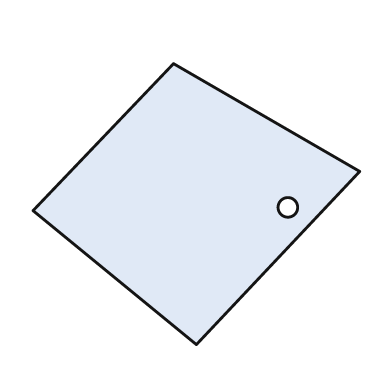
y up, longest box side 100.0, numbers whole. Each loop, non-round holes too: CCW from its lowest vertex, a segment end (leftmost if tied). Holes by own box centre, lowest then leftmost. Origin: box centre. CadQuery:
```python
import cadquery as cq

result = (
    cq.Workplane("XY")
    .moveTo(0.0, -43.0)
    .lineTo(50.0, 10.0)
    .lineTo(-7.0, 43.0)
    .lineTo(-50.0, -2.0)
    .close()
    .moveTo(28.0, -1.0)
    .circle(3.0)
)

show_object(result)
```